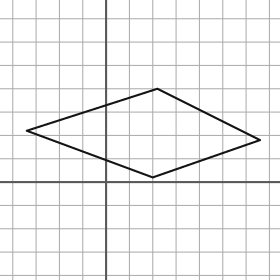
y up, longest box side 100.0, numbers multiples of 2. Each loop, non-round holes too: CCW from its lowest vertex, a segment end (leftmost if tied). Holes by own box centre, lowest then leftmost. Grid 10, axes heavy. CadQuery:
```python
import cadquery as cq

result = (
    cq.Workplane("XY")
    .moveTo(20.0, 2.0)
    .lineTo(66.0, 18.0)
    .lineTo(22.0, 40.0)
    .lineTo(-34.0, 22.0)
    .close()
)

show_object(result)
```